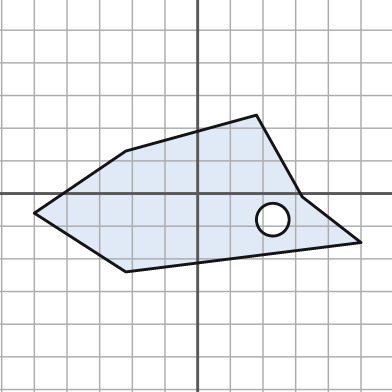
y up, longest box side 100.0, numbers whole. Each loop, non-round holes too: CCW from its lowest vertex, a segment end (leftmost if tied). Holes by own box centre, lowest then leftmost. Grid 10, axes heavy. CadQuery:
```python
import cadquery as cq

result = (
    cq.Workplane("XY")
    .moveTo(-22.0, -24.0)
    .lineTo(50.0, -15.0)
    .lineTo(32.0, -1.0)
    .lineTo(18.0, 24.0)
    .lineTo(-22.0, 13.0)
    .lineTo(-50.0, -6.0)
    .close()
    .moveTo(23.0, -8.0)
    .circle(5.0)
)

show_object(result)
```